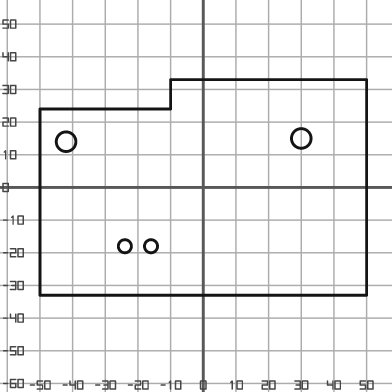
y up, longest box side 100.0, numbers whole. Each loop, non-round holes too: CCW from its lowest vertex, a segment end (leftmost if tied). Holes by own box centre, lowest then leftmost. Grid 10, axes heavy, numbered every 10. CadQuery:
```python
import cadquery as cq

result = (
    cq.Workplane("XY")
    .moveTo(-50.0, -33.0)
    .lineTo(50.0, -33.0)
    .lineTo(50.0, 33.0)
    .lineTo(-10.0, 33.0)
    .lineTo(-10.0, 24.0)
    .lineTo(-50.0, 24.0)
    .close()
    .moveTo(-24.0, -18.0)
    .circle(2.0)
    .moveTo(-16.0, -18.0)
    .circle(2.0)
    .moveTo(-42.0, 14.0)
    .circle(3.0)
    .moveTo(30.0, 15.0)
    .circle(3.0)
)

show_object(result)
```